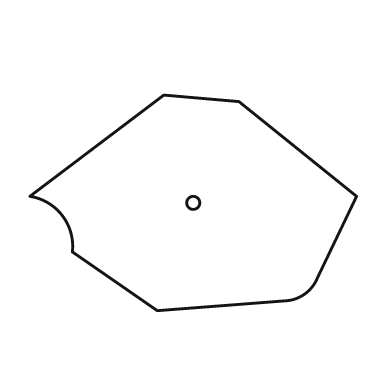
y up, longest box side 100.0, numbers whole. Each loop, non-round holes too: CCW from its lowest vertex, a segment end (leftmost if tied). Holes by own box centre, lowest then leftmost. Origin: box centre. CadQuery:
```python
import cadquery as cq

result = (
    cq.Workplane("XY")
    .moveTo(-11.0, -33.0)
    .lineTo(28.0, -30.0)
    .threePointArc((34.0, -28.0), (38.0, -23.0))
    .lineTo(50.0, 2.0)
    .lineTo(14.0, 31.0)
    .lineTo(-9.0, 33.0)
    .lineTo(-50.0, 2.0)
    .threePointArc((-40.0, -4.0), (-37.0, -15.0))
    .close()
    .moveTo(0.0, 0.0)
    .circle(2.0)
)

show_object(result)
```